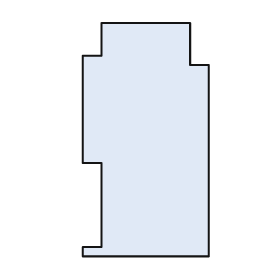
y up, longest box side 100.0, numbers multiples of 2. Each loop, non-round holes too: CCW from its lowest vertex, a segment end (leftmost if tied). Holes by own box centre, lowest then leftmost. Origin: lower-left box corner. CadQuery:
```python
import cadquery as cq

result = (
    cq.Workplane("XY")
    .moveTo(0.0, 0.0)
    .lineTo(54.0, 0.0)
    .lineTo(54.0, 82.0)
    .lineTo(46.0, 82.0)
    .lineTo(46.0, 100.0)
    .lineTo(8.0, 100.0)
    .lineTo(8.0, 86.0)
    .lineTo(0.0, 86.0)
    .lineTo(0.0, 40.0)
    .lineTo(8.0, 40.0)
    .lineTo(8.0, 4.0)
    .lineTo(0.0, 4.0)
    .close()
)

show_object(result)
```